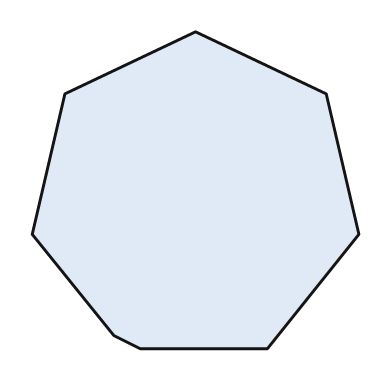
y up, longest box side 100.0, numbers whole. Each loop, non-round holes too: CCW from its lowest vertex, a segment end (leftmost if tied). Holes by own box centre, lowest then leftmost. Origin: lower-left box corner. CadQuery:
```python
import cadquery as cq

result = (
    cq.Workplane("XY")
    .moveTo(33.0, 0.0)
    .lineTo(72.0, 0.0)
    .lineTo(100.0, 35.0)
    .lineTo(90.0, 78.0)
    .lineTo(50.0, 97.0)
    .lineTo(10.0, 78.0)
    .lineTo(0.0, 35.0)
    .lineTo(25.0, 4.0)
    .close()
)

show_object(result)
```